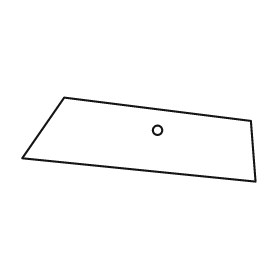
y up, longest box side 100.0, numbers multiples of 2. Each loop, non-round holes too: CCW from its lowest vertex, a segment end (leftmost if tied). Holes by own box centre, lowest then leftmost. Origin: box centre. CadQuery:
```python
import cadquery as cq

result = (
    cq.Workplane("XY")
    .moveTo(50.0, -18.0)
    .lineTo(48.0, 8.0)
    .lineTo(-32.0, 18.0)
    .lineTo(-50.0, -8.0)
    .close()
    .moveTo(8.0, 4.0)
    .circle(2.0)
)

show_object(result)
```